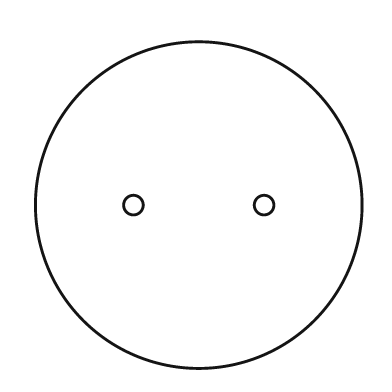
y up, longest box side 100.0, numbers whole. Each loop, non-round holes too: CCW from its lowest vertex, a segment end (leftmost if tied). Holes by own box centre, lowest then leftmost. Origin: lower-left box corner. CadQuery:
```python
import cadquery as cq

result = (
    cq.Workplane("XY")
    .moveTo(50.0, 50.0)
    .circle(50.0)
    .moveTo(30.0, 50.0)
    .circle(3.0)
    .moveTo(70.0, 50.0)
    .circle(3.0)
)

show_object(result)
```